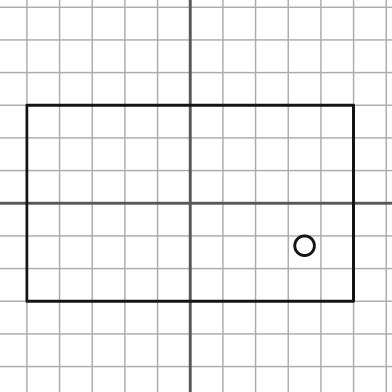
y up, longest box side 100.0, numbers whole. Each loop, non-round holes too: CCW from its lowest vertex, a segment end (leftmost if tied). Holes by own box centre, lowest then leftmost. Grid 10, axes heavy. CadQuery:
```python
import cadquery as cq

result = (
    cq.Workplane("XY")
    .moveTo(-50.0, -30.0)
    .lineTo(50.0, -30.0)
    .lineTo(50.0, 30.0)
    .lineTo(-50.0, 30.0)
    .close()
    .moveTo(35.0, -13.0)
    .circle(3.0)
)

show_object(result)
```